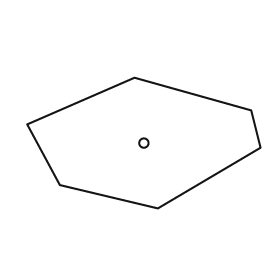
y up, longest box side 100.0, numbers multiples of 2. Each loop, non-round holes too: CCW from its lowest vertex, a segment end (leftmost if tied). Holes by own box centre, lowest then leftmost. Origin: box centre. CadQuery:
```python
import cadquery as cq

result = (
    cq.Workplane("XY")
    .moveTo(6.0, -28.0)
    .lineTo(50.0, -2.0)
    .lineTo(46.0, 14.0)
    .lineTo(-4.0, 28.0)
    .lineTo(-50.0, 8.0)
    .lineTo(-36.0, -18.0)
    .close()
    .moveTo(0.0, 0.0)
    .circle(2.0)
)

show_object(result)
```